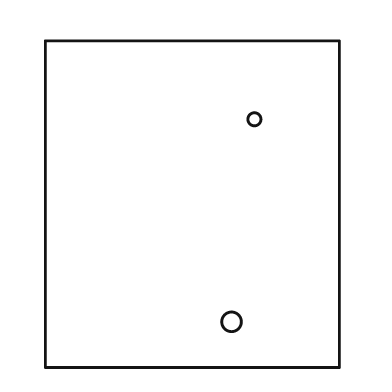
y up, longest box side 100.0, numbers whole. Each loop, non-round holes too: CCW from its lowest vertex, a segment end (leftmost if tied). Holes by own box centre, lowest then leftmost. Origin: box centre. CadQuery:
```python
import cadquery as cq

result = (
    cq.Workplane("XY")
    .moveTo(-45.0, -50.0)
    .lineTo(45.0, -50.0)
    .lineTo(45.0, 50.0)
    .lineTo(-45.0, 50.0)
    .close()
    .moveTo(12.0, -36.0)
    .circle(3.0)
    .moveTo(19.0, 26.0)
    .circle(2.0)
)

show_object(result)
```